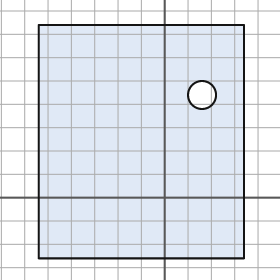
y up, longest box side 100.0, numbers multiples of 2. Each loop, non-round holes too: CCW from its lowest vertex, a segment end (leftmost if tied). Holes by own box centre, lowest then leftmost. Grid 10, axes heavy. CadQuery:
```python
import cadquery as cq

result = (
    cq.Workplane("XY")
    .moveTo(-54.0, -26.0)
    .lineTo(34.0, -26.0)
    .lineTo(34.0, 74.0)
    .lineTo(-54.0, 74.0)
    .close()
    .moveTo(16.0, 44.0)
    .circle(6.0)
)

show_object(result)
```